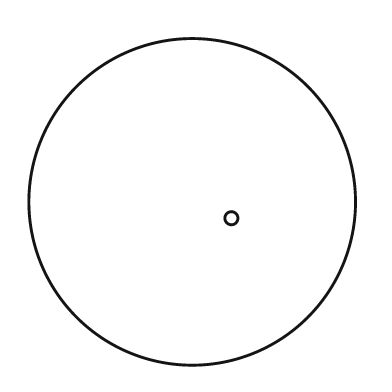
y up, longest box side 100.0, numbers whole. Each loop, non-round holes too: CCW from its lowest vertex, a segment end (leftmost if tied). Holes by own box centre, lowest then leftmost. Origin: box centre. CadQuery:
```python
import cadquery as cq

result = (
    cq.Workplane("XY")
    .moveTo(0.0, 0.0)
    .circle(50.0)
    .moveTo(12.0, -5.0)
    .circle(2.0)
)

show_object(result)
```